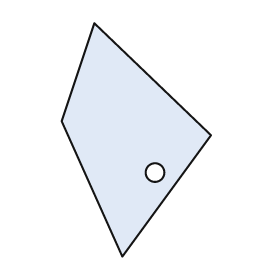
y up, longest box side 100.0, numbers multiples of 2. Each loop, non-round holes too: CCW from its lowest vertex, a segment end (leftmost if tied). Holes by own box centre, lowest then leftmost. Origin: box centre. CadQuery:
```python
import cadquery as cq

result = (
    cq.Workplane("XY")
    .moveTo(-6.0, -50.0)
    .lineTo(32.0, 2.0)
    .lineTo(-18.0, 50.0)
    .lineTo(-32.0, 8.0)
    .close()
    .moveTo(8.0, -14.0)
    .circle(4.0)
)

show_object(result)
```